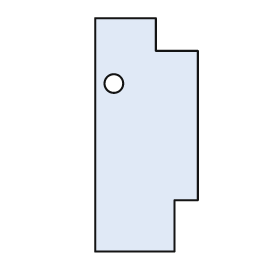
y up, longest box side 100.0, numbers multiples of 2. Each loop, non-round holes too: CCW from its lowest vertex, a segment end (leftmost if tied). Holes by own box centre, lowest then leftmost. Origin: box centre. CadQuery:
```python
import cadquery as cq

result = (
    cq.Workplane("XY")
    .moveTo(-22.0, -50.0)
    .lineTo(12.0, -50.0)
    .lineTo(12.0, -28.0)
    .lineTo(22.0, -28.0)
    .lineTo(22.0, 36.0)
    .lineTo(4.0, 36.0)
    .lineTo(4.0, 50.0)
    .lineTo(-22.0, 50.0)
    .close()
    .moveTo(-14.0, 22.0)
    .circle(4.0)
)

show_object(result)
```